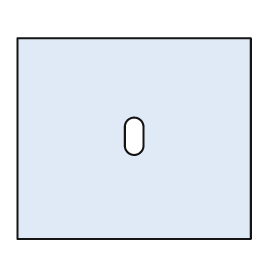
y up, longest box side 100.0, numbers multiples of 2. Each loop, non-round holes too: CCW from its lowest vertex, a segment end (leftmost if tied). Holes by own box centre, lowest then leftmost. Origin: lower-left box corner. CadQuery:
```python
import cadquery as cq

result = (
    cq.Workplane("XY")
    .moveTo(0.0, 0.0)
    .lineTo(100.0, 0.0)
    .lineTo(100.0, 86.0)
    .lineTo(0.0, 86.0)
    .close()
    .moveTo(46.0, 40.0)
    .threePointArc((50.0, 36.0), (54.0, 40.0))
    .lineTo(54.0, 48.0)
    .threePointArc((50.0, 52.0), (46.0, 48.0))
    .close()
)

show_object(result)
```